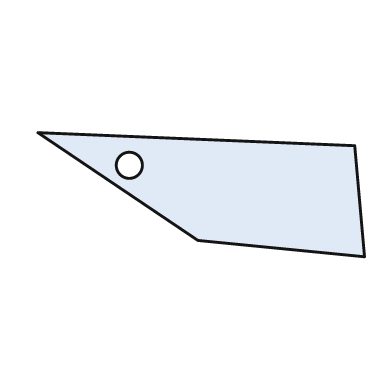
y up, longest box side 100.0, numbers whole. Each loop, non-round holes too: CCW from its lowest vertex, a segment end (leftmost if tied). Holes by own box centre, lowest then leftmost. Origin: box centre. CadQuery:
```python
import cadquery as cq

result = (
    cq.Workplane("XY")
    .moveTo(50.0, -19.0)
    .lineTo(47.0, 15.0)
    .lineTo(-50.0, 19.0)
    .lineTo(-1.0, -14.0)
    .close()
    .moveTo(-22.0, 9.0)
    .circle(4.0)
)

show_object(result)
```